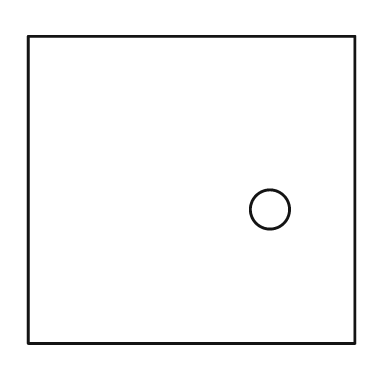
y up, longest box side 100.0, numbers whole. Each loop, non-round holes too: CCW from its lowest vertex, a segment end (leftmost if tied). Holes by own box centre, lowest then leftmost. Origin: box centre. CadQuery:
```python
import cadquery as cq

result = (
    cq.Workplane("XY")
    .moveTo(-50.0, -47.0)
    .lineTo(50.0, -47.0)
    .lineTo(50.0, 47.0)
    .lineTo(-50.0, 47.0)
    .close()
    .moveTo(24.0, -6.0)
    .circle(6.0)
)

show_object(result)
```